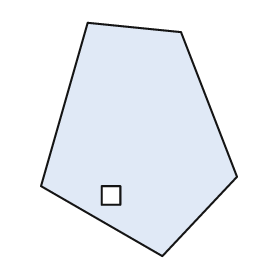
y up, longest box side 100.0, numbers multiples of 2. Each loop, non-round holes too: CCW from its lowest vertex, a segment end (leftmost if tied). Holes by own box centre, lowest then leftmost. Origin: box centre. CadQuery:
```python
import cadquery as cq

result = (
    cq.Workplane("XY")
    .moveTo(10.0, -50.0)
    .lineTo(42.0, -16.0)
    .lineTo(18.0, 46.0)
    .lineTo(-22.0, 50.0)
    .lineTo(-42.0, -20.0)
    .close()
    .moveTo(-16.0, -28.0)
    .lineTo(-8.0, -28.0)
    .lineTo(-8.0, -20.0)
    .lineTo(-16.0, -20.0)
    .close()
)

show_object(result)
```